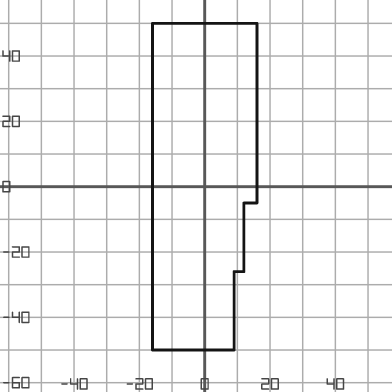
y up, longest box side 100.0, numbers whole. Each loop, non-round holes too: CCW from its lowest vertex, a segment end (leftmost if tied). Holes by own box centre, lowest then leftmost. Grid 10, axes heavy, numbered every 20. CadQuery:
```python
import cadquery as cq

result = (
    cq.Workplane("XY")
    .moveTo(-16.0, -50.0)
    .lineTo(9.0, -50.0)
    .lineTo(9.0, -26.0)
    .lineTo(12.0, -26.0)
    .lineTo(12.0, -5.0)
    .lineTo(16.0, -5.0)
    .lineTo(16.0, 50.0)
    .lineTo(-16.0, 50.0)
    .close()
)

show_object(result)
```